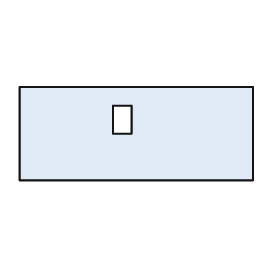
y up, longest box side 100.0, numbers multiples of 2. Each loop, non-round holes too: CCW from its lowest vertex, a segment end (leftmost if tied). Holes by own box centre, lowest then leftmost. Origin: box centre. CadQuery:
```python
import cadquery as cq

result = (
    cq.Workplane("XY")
    .moveTo(-50.0, -20.0)
    .lineTo(50.0, -20.0)
    .lineTo(50.0, 20.0)
    .lineTo(-50.0, 20.0)
    .close()
    .moveTo(-10.0, 0.0)
    .lineTo(-2.0, 0.0)
    .lineTo(-2.0, 12.0)
    .lineTo(-10.0, 12.0)
    .close()
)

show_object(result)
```